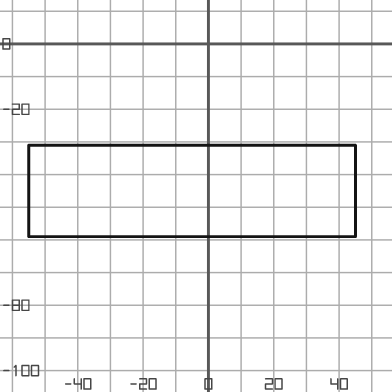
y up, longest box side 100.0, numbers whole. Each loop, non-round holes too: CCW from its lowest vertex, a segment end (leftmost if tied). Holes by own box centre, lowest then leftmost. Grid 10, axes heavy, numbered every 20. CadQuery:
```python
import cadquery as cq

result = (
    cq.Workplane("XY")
    .moveTo(-55.0, -59.0)
    .lineTo(45.0, -59.0)
    .lineTo(45.0, -31.0)
    .lineTo(-55.0, -31.0)
    .close()
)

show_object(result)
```